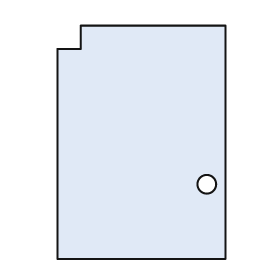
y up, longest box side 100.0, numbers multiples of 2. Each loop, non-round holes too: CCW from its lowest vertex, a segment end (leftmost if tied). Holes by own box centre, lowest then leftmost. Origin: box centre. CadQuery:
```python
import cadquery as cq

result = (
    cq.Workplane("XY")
    .moveTo(-36.0, -50.0)
    .lineTo(36.0, -50.0)
    .lineTo(36.0, 50.0)
    .lineTo(-26.0, 50.0)
    .lineTo(-26.0, 40.0)
    .lineTo(-36.0, 40.0)
    .close()
    .moveTo(28.0, -18.0)
    .circle(4.0)
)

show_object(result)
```